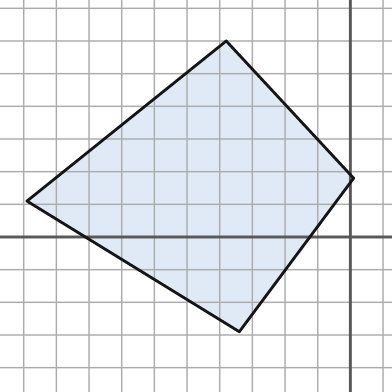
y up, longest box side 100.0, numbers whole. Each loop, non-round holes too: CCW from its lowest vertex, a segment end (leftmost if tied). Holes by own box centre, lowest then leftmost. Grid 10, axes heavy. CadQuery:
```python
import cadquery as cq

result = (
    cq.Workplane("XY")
    .moveTo(-34.0, -29.0)
    .lineTo(1.0, 18.0)
    .lineTo(-38.0, 60.0)
    .lineTo(-99.0, 11.0)
    .close()
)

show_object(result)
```